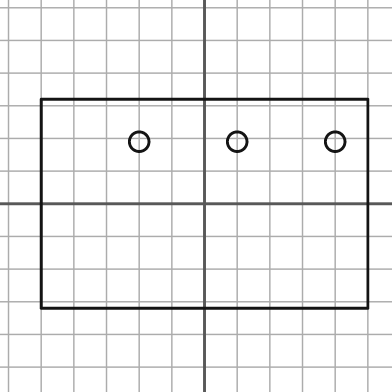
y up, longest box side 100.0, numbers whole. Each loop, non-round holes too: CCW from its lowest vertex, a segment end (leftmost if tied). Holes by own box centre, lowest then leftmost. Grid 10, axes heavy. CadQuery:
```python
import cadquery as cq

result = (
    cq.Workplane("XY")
    .moveTo(-50.0, -32.0)
    .lineTo(50.0, -32.0)
    .lineTo(50.0, 32.0)
    .lineTo(-50.0, 32.0)
    .close()
    .moveTo(-20.0, 19.0)
    .circle(3.0)
    .moveTo(10.0, 19.0)
    .circle(3.0)
    .moveTo(40.0, 19.0)
    .circle(3.0)
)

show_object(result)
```